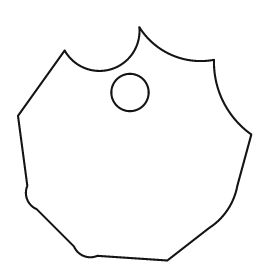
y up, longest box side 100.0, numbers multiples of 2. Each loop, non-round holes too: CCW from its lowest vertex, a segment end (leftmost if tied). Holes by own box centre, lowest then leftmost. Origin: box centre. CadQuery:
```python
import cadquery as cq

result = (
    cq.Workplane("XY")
    .moveTo(14.0, -50.0)
    .lineTo(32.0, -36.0)
    .threePointArc((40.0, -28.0), (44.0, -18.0))
    .lineTo(50.0, 4.0)
    .threePointArc((38.0, 18.0), (34.0, 36.0))
    .threePointArc((16.0, 38.0), (2.0, 50.0))
    .threePointArc((-10.0, 32.0), (-30.0, 40.0))
    .lineTo(-50.0, 12.0)
    .lineTo(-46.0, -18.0)
    .threePointArc((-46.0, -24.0), (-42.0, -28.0))
    .lineTo(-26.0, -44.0)
    .threePointArc((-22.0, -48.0), (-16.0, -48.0))
    .close()
    .moveTo(-2.0, 22.0)
    .circle(8.0)
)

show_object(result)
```